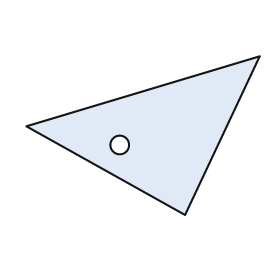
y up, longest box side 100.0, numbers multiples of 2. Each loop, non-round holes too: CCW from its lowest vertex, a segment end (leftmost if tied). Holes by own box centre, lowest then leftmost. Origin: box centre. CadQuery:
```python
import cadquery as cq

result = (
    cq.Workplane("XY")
    .moveTo(18.0, -34.0)
    .lineTo(50.0, 34.0)
    .lineTo(-50.0, 4.0)
    .close()
    .moveTo(-10.0, -4.0)
    .circle(4.0)
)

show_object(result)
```